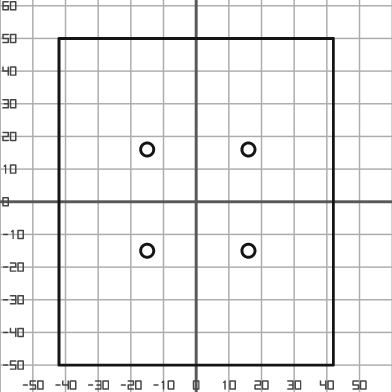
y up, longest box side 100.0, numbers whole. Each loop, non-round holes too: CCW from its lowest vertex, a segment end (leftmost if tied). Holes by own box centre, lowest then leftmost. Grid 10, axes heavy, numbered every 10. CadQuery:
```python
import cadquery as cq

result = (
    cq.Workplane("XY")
    .moveTo(-42.0, -50.0)
    .lineTo(42.0, -50.0)
    .lineTo(42.0, 50.0)
    .lineTo(-42.0, 50.0)
    .close()
    .moveTo(-15.0, -15.0)
    .circle(2.0)
    .moveTo(16.0, -15.0)
    .circle(2.0)
    .moveTo(-15.0, 16.0)
    .circle(2.0)
    .moveTo(16.0, 16.0)
    .circle(2.0)
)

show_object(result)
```